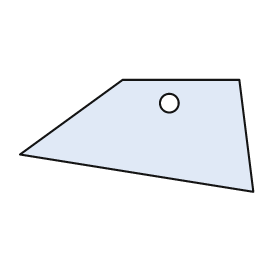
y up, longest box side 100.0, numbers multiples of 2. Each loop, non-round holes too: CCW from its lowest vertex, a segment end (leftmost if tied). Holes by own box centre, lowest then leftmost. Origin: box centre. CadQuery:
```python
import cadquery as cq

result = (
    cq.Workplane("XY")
    .moveTo(50.0, -24.0)
    .lineTo(44.0, 24.0)
    .lineTo(-6.0, 24.0)
    .lineTo(-50.0, -8.0)
    .close()
    .moveTo(14.0, 14.0)
    .circle(4.0)
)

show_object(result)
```